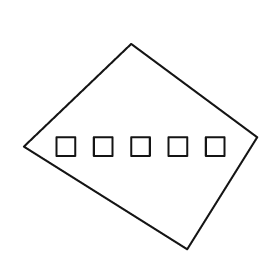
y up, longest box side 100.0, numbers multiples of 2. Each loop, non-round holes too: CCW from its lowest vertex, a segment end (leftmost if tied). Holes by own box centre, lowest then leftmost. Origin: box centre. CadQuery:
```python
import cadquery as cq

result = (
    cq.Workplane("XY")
    .moveTo(20.0, -44.0)
    .lineTo(50.0, 4.0)
    .lineTo(-4.0, 44.0)
    .lineTo(-50.0, 0.0)
    .close()
    .moveTo(-36.0, -4.0)
    .lineTo(-28.0, -4.0)
    .lineTo(-28.0, 4.0)
    .lineTo(-36.0, 4.0)
    .close()
    .moveTo(-20.0, -4.0)
    .lineTo(-12.0, -4.0)
    .lineTo(-12.0, 4.0)
    .lineTo(-20.0, 4.0)
    .close()
    .moveTo(-4.0, -4.0)
    .lineTo(4.0, -4.0)
    .lineTo(4.0, 4.0)
    .lineTo(-4.0, 4.0)
    .close()
    .moveTo(12.0, -4.0)
    .lineTo(20.0, -4.0)
    .lineTo(20.0, 4.0)
    .lineTo(12.0, 4.0)
    .close()
    .moveTo(28.0, -4.0)
    .lineTo(36.0, -4.0)
    .lineTo(36.0, 4.0)
    .lineTo(28.0, 4.0)
    .close()
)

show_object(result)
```